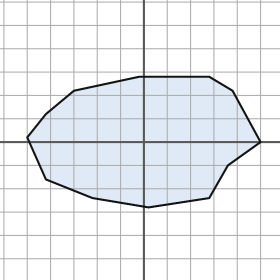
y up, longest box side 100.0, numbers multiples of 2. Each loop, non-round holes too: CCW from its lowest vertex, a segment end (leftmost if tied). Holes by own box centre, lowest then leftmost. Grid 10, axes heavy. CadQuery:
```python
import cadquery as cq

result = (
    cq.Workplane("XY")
    .moveTo(2.0, -28.0)
    .lineTo(28.0, -24.0)
    .lineTo(36.0, -10.0)
    .lineTo(50.0, 0.0)
    .lineTo(38.0, 22.0)
    .lineTo(28.0, 28.0)
    .lineTo(-2.0, 28.0)
    .lineTo(-30.0, 22.0)
    .lineTo(-42.0, 12.0)
    .lineTo(-50.0, 2.0)
    .lineTo(-42.0, -16.0)
    .lineTo(-22.0, -24.0)
    .close()
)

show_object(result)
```